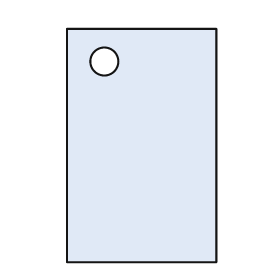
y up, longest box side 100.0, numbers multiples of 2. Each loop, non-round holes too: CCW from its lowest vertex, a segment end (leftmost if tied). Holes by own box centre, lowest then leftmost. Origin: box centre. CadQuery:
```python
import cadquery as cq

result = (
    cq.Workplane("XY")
    .moveTo(-32.0, -50.0)
    .lineTo(32.0, -50.0)
    .lineTo(32.0, 50.0)
    .lineTo(-32.0, 50.0)
    .close()
    .moveTo(-16.0, 36.0)
    .circle(6.0)
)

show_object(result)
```